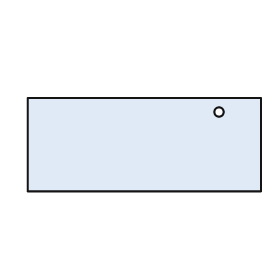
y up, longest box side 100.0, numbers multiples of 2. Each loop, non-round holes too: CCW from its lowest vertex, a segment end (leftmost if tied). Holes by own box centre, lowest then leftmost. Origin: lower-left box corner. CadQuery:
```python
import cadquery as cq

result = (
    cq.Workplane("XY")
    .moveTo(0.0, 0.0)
    .lineTo(100.0, 0.0)
    .lineTo(100.0, 40.0)
    .lineTo(0.0, 40.0)
    .close()
    .moveTo(82.0, 34.0)
    .circle(2.0)
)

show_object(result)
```